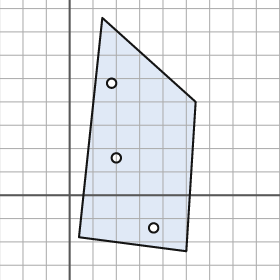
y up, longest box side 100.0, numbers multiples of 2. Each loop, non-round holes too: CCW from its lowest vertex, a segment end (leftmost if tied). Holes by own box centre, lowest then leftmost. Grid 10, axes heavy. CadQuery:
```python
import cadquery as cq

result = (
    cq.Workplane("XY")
    .moveTo(50.0, -24.0)
    .lineTo(54.0, 40.0)
    .lineTo(14.0, 76.0)
    .lineTo(4.0, -18.0)
    .close()
    .moveTo(36.0, -14.0)
    .circle(2.0)
    .moveTo(20.0, 16.0)
    .circle(2.0)
    .moveTo(18.0, 48.0)
    .circle(2.0)
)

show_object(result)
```